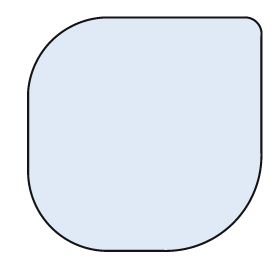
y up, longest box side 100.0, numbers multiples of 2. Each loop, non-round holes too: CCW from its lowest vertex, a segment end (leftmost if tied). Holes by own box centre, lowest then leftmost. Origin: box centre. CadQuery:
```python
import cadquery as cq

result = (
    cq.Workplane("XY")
    .moveTo(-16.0, -50.0)
    .lineTo(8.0, -50.0)
    .threePointArc((38.0, -38.0), (50.0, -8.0))
    .lineTo(50.0, 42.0)
    .threePointArc((48.0, 48.0), (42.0, 50.0))
    .lineTo(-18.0, 50.0)
    .threePointArc((-40.0, 40.0), (-50.0, 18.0))
    .lineTo(-50.0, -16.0)
    .threePointArc((-40.0, -40.0), (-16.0, -50.0))
    .close()
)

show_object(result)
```